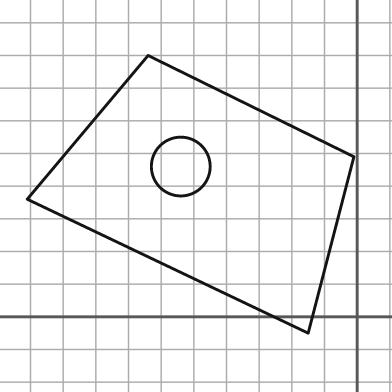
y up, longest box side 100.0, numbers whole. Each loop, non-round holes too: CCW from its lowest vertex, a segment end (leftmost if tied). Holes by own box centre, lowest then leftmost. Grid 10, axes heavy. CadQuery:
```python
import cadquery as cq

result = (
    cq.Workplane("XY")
    .moveTo(-15.0, -5.0)
    .lineTo(-1.0, 49.0)
    .lineTo(-64.0, 80.0)
    .lineTo(-101.0, 36.0)
    .close()
    .moveTo(-54.0, 46.0)
    .circle(9.0)
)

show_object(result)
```